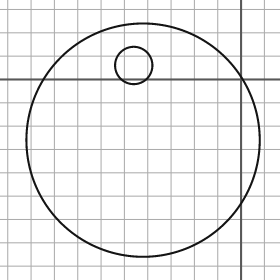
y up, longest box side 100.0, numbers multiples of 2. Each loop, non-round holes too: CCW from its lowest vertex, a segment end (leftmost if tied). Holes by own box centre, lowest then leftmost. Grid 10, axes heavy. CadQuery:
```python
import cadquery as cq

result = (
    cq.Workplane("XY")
    .moveTo(-42.0, -26.0)
    .circle(50.0)
    .moveTo(-46.0, 6.0)
    .circle(8.0)
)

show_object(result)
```